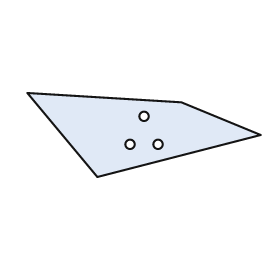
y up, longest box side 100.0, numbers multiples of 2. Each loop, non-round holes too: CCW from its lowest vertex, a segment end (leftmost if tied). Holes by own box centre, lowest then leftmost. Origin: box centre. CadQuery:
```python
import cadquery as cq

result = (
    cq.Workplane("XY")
    .moveTo(-20.0, -18.0)
    .lineTo(50.0, 0.0)
    .lineTo(16.0, 14.0)
    .lineTo(-50.0, 18.0)
    .close()
    .moveTo(-6.0, -4.0)
    .circle(2.0)
    .moveTo(6.0, -4.0)
    .circle(2.0)
    .moveTo(0.0, 8.0)
    .circle(2.0)
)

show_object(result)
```